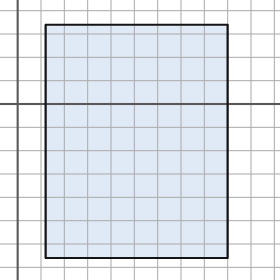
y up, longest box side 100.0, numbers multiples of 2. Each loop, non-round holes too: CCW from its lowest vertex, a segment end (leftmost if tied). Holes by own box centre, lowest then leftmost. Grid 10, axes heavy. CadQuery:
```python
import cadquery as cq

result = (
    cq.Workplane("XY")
    .moveTo(12.0, -66.0)
    .lineTo(90.0, -66.0)
    .lineTo(90.0, 34.0)
    .lineTo(12.0, 34.0)
    .close()
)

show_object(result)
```